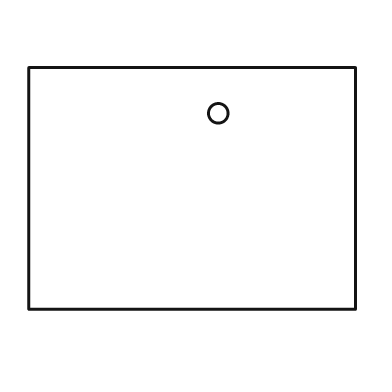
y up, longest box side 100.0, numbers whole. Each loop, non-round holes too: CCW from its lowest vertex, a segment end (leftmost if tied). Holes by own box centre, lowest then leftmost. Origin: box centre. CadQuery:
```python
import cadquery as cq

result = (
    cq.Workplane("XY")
    .moveTo(-50.0, -37.0)
    .lineTo(50.0, -37.0)
    .lineTo(50.0, 37.0)
    .lineTo(-50.0, 37.0)
    .close()
    .moveTo(8.0, 23.0)
    .circle(3.0)
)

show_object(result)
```